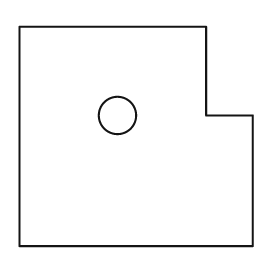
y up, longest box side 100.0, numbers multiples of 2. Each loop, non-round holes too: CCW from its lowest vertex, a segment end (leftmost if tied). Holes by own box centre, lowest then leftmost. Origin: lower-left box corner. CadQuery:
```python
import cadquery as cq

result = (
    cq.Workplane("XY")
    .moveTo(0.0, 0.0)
    .lineTo(100.0, 0.0)
    .lineTo(100.0, 56.0)
    .lineTo(80.0, 56.0)
    .lineTo(80.0, 94.0)
    .lineTo(0.0, 94.0)
    .close()
    .moveTo(42.0, 56.0)
    .circle(8.0)
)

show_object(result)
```